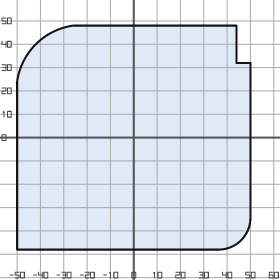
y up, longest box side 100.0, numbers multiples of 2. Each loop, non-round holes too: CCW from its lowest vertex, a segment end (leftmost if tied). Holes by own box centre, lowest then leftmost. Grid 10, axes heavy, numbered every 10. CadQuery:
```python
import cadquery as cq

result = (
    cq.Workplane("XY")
    .moveTo(-50.0, -48.0)
    .lineTo(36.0, -48.0)
    .threePointArc((46.0, -44.0), (50.0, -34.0))
    .lineTo(50.0, 32.0)
    .lineTo(44.0, 32.0)
    .lineTo(44.0, 48.0)
    .lineTo(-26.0, 48.0)
    .threePointArc((-42.0, 40.0), (-50.0, 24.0))
    .close()
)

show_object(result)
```